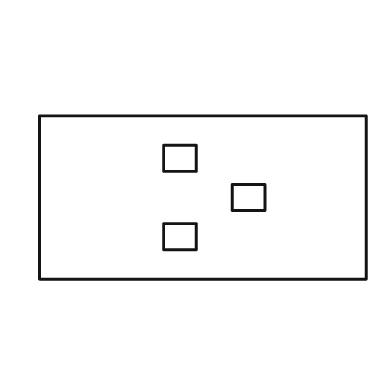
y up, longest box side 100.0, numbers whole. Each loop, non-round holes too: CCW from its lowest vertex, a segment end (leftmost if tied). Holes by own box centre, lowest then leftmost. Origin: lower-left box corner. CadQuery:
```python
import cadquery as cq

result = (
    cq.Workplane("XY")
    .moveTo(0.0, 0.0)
    .lineTo(100.0, 0.0)
    .lineTo(100.0, 50.0)
    .lineTo(0.0, 50.0)
    .close()
    .moveTo(38.0, 9.0)
    .lineTo(48.0, 9.0)
    .lineTo(48.0, 17.0)
    .lineTo(38.0, 17.0)
    .close()
    .moveTo(59.0, 21.0)
    .lineTo(69.0, 21.0)
    .lineTo(69.0, 29.0)
    .lineTo(59.0, 29.0)
    .close()
    .moveTo(38.0, 33.0)
    .lineTo(48.0, 33.0)
    .lineTo(48.0, 41.0)
    .lineTo(38.0, 41.0)
    .close()
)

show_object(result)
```